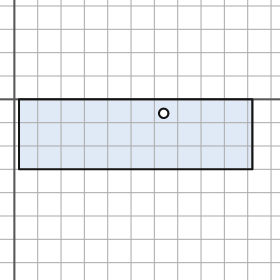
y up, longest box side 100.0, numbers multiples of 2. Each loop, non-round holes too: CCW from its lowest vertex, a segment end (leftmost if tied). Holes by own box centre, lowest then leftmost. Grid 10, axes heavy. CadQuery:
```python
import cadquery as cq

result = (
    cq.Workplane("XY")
    .moveTo(2.0, -30.0)
    .lineTo(102.0, -30.0)
    .lineTo(102.0, 0.0)
    .lineTo(2.0, 0.0)
    .close()
    .moveTo(64.0, -6.0)
    .circle(2.0)
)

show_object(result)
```